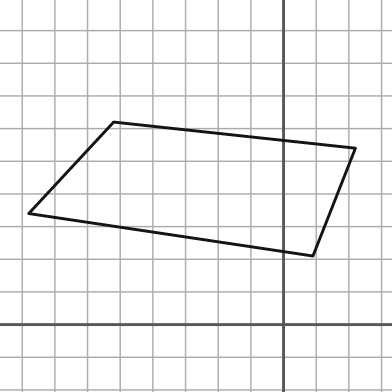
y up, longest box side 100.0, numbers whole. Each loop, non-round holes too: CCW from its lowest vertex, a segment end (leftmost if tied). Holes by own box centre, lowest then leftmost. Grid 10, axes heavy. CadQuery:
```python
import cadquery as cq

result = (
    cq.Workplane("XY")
    .moveTo(9.0, 21.0)
    .lineTo(22.0, 54.0)
    .lineTo(-52.0, 62.0)
    .lineTo(-78.0, 34.0)
    .close()
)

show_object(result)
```